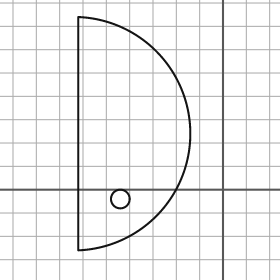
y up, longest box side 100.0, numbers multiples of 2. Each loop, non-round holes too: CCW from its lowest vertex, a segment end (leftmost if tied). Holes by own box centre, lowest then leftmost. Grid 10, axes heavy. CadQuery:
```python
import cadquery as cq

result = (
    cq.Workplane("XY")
    .moveTo(-62.0, -26.0)
    .threePointArc((-14.0, 24.0), (-62.0, 74.0))
    .close()
    .moveTo(-44.0, -4.0)
    .circle(4.0)
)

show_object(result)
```